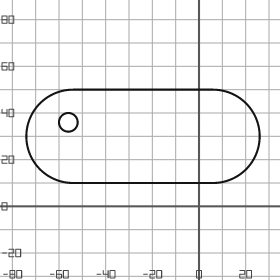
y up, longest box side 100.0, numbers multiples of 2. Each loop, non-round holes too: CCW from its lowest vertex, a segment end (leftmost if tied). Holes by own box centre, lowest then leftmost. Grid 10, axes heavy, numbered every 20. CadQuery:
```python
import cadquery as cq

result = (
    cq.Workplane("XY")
    .moveTo(-54.0, 10.0)
    .lineTo(6.0, 10.0)
    .threePointArc((26.0, 30.0), (6.0, 50.0))
    .lineTo(-54.0, 50.0)
    .threePointArc((-74.0, 30.0), (-54.0, 10.0))
    .close()
    .moveTo(-56.0, 36.0)
    .circle(4.0)
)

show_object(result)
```